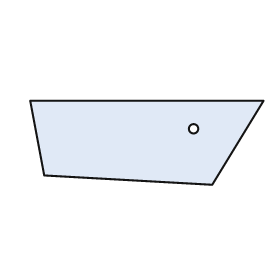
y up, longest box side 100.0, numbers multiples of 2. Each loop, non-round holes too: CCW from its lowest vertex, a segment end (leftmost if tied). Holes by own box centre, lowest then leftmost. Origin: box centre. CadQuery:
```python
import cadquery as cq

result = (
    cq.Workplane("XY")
    .moveTo(28.0, -18.0)
    .lineTo(50.0, 18.0)
    .lineTo(-50.0, 18.0)
    .lineTo(-44.0, -14.0)
    .close()
    .moveTo(20.0, 6.0)
    .circle(2.0)
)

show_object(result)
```